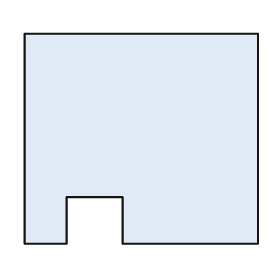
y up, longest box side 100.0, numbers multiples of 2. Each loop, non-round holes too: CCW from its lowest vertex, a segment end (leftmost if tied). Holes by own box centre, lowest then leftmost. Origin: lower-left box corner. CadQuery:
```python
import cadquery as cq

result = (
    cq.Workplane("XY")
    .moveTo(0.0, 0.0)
    .lineTo(18.0, 0.0)
    .lineTo(18.0, 20.0)
    .lineTo(42.0, 20.0)
    .lineTo(42.0, 0.0)
    .lineTo(100.0, 0.0)
    .lineTo(100.0, 90.0)
    .lineTo(0.0, 90.0)
    .close()
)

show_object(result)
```